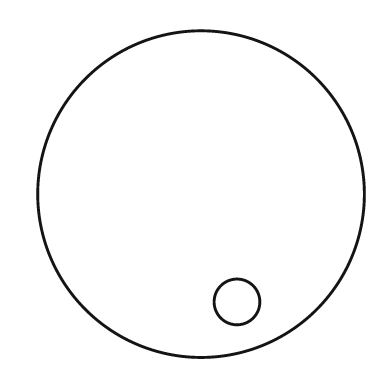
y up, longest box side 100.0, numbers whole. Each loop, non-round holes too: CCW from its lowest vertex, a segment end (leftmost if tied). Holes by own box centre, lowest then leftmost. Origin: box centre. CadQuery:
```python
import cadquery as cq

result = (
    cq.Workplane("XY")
    .moveTo(0.0, 0.0)
    .circle(50.0)
    .moveTo(11.0, -33.0)
    .circle(7.0)
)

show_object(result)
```